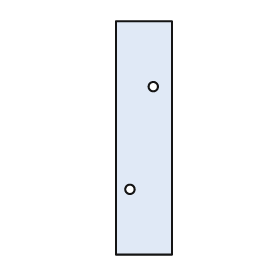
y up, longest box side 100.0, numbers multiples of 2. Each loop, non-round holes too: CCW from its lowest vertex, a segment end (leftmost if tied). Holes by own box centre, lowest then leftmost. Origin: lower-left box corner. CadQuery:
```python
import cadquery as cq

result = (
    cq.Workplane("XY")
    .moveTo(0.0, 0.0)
    .lineTo(24.0, 0.0)
    .lineTo(24.0, 100.0)
    .lineTo(0.0, 100.0)
    .close()
    .moveTo(6.0, 28.0)
    .circle(2.0)
    .moveTo(16.0, 72.0)
    .circle(2.0)
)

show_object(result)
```